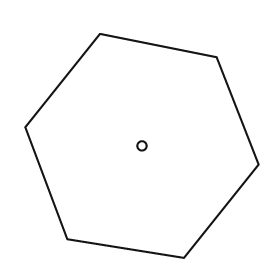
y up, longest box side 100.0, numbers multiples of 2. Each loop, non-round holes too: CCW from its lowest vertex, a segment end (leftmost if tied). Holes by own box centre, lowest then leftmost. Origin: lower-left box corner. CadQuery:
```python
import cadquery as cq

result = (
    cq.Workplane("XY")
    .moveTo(68.0, 0.0)
    .lineTo(100.0, 40.0)
    .lineTo(82.0, 86.0)
    .lineTo(32.0, 96.0)
    .lineTo(0.0, 56.0)
    .lineTo(18.0, 8.0)
    .close()
    .moveTo(50.0, 48.0)
    .circle(2.0)
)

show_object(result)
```